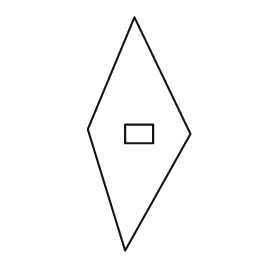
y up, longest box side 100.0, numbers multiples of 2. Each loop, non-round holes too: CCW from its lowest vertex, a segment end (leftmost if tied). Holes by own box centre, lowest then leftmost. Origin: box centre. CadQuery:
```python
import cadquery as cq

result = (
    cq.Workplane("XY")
    .moveTo(-6.0, -50.0)
    .lineTo(22.0, 0.0)
    .lineTo(-2.0, 50.0)
    .lineTo(-22.0, 2.0)
    .close()
    .moveTo(-6.0, -4.0)
    .lineTo(6.0, -4.0)
    .lineTo(6.0, 4.0)
    .lineTo(-6.0, 4.0)
    .close()
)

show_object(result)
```